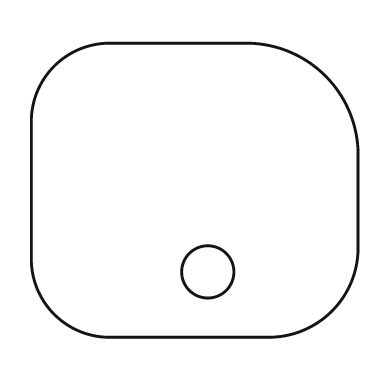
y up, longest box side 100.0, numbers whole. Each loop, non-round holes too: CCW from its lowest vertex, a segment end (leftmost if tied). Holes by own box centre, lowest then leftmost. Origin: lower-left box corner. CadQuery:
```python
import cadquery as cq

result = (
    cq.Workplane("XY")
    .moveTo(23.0, 0.0)
    .lineTo(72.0, 0.0)
    .threePointArc((92.0, 8.0), (100.0, 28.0))
    .lineTo(100.0, 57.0)
    .threePointArc((90.0, 80.0), (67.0, 90.0))
    .lineTo(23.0, 90.0)
    .threePointArc((7.0, 83.0), (0.0, 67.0))
    .lineTo(0.0, 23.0)
    .threePointArc((7.0, 7.0), (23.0, 0.0))
    .close()
    .moveTo(54.0, 20.0)
    .circle(8.0)
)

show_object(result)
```